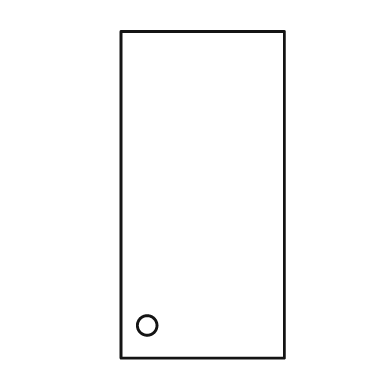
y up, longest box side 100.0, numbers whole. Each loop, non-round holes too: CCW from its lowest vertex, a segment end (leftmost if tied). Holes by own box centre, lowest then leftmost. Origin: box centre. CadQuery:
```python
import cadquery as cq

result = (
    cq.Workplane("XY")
    .moveTo(-25.0, -50.0)
    .lineTo(25.0, -50.0)
    .lineTo(25.0, 50.0)
    .lineTo(-25.0, 50.0)
    .close()
    .moveTo(-17.0, -40.0)
    .circle(3.0)
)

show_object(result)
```